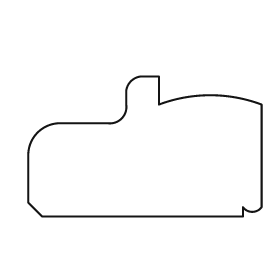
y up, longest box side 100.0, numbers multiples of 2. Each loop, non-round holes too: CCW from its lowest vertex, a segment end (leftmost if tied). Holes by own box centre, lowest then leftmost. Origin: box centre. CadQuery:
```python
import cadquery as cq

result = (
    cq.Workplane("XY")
    .moveTo(-44.0, -30.0)
    .lineTo(42.0, -30.0)
    .lineTo(42.0, -26.0)
    .threePointArc((46.0, -28.0), (50.0, -26.0))
    .lineTo(50.0, 18.0)
    .threePointArc((28.0, 22.0), (6.0, 18.0))
    .lineTo(6.0, 30.0)
    .lineTo(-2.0, 30.0)
    .threePointArc((-6.0, 28.0), (-8.0, 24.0))
    .lineTo(-8.0, 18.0)
    .threePointArc((-10.0, 12.0), (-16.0, 10.0))
    .lineTo(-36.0, 10.0)
    .threePointArc((-46.0, 6.0), (-50.0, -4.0))
    .lineTo(-50.0, -24.0)
    .close()
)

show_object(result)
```